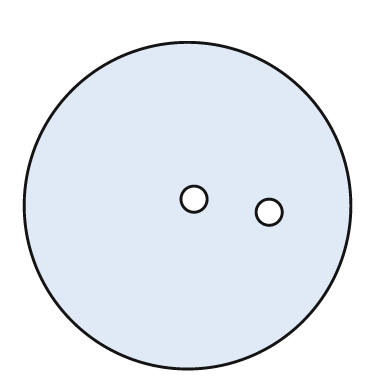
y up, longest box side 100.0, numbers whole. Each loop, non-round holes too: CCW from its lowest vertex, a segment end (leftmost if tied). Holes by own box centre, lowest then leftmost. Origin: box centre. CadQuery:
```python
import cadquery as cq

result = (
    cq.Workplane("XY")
    .moveTo(0.0, 0.0)
    .circle(50.0)
    .moveTo(25.0, -2.0)
    .circle(4.0)
    .moveTo(2.0, 2.0)
    .circle(4.0)
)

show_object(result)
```